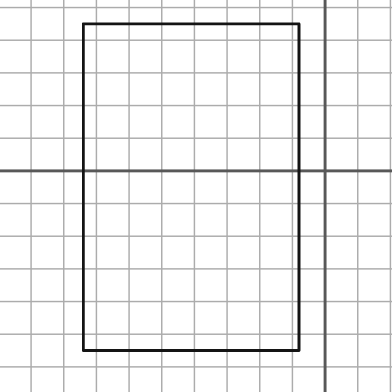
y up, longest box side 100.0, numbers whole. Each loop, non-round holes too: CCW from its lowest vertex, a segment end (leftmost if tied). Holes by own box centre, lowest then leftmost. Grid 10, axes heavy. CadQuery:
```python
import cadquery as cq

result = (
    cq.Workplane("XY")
    .moveTo(-74.0, -55.0)
    .lineTo(-8.0, -55.0)
    .lineTo(-8.0, 45.0)
    .lineTo(-74.0, 45.0)
    .close()
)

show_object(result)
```